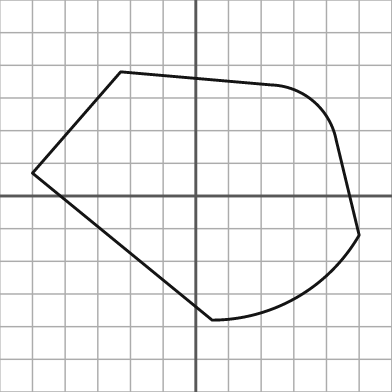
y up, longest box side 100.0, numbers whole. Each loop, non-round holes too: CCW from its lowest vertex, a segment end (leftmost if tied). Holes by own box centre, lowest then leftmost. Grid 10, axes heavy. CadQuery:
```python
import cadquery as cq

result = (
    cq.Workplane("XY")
    .moveTo(5.0, -38.0)
    .threePointArc((31.0, -31.0), (50.0, -12.0))
    .lineTo(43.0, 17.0)
    .threePointArc((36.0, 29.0), (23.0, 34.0))
    .lineTo(-23.0, 38.0)
    .lineTo(-50.0, 7.0)
    .close()
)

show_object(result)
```